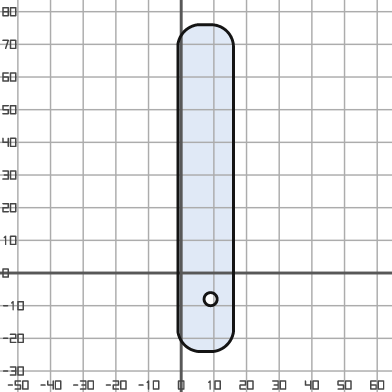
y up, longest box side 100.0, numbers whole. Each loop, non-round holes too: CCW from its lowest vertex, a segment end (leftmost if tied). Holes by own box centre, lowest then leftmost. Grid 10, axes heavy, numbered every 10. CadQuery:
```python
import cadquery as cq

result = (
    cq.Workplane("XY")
    .moveTo(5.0, -24.0)
    .lineTo(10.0, -24.0)
    .threePointArc((14.0, -22.0), (16.0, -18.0))
    .lineTo(16.0, 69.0)
    .threePointArc((14.0, 74.0), (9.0, 76.0))
    .lineTo(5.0, 76.0)
    .threePointArc((1.0, 74.0), (-1.0, 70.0))
    .lineTo(-1.0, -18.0)
    .threePointArc((1.0, -22.0), (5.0, -24.0))
    .close()
    .moveTo(9.0, -8.0)
    .circle(2.0)
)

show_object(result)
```